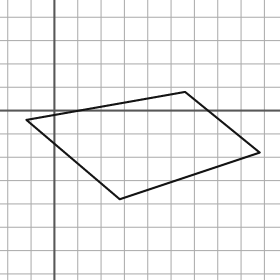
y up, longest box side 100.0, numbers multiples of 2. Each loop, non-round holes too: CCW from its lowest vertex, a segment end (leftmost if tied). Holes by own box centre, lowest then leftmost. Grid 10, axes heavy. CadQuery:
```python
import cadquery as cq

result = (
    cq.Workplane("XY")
    .moveTo(28.0, -38.0)
    .lineTo(88.0, -18.0)
    .lineTo(56.0, 8.0)
    .lineTo(-12.0, -4.0)
    .close()
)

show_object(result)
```